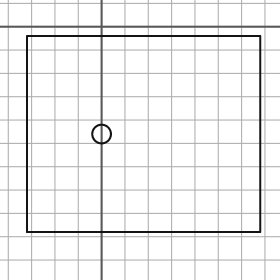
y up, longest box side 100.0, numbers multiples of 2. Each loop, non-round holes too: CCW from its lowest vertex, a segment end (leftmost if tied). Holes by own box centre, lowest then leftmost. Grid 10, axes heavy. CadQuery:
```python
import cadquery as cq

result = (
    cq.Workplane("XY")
    .moveTo(-32.0, -88.0)
    .lineTo(68.0, -88.0)
    .lineTo(68.0, -4.0)
    .lineTo(-32.0, -4.0)
    .close()
    .moveTo(0.0, -46.0)
    .circle(4.0)
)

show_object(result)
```